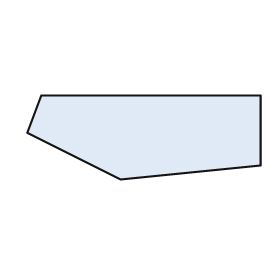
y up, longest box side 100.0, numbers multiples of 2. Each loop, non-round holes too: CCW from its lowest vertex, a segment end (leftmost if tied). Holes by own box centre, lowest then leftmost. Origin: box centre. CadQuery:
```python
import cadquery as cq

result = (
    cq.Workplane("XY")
    .moveTo(-10.0, -18.0)
    .lineTo(50.0, -12.0)
    .lineTo(50.0, 18.0)
    .lineTo(-44.0, 18.0)
    .lineTo(-50.0, 2.0)
    .close()
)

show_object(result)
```